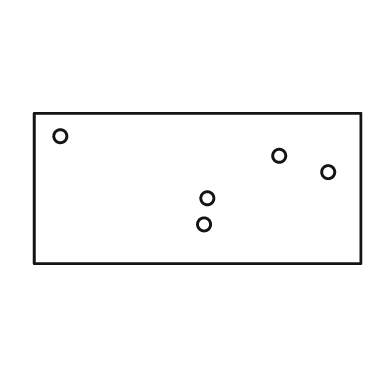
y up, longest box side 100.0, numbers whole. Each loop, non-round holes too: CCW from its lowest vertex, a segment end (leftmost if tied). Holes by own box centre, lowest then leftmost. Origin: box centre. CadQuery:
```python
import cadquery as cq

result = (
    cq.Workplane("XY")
    .moveTo(-50.0, -23.0)
    .lineTo(50.0, -23.0)
    .lineTo(50.0, 23.0)
    .lineTo(-50.0, 23.0)
    .close()
    .moveTo(2.0, -11.0)
    .circle(2.0)
    .moveTo(3.0, -3.0)
    .circle(2.0)
    .moveTo(40.0, 5.0)
    .circle(2.0)
    .moveTo(25.0, 10.0)
    .circle(2.0)
    .moveTo(-42.0, 16.0)
    .circle(2.0)
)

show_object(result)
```